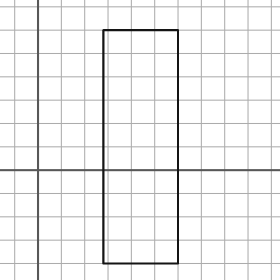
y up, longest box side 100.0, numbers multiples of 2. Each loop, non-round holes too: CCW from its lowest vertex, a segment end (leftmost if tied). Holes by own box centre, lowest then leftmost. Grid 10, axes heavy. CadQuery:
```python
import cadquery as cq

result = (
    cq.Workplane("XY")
    .moveTo(28.0, -40.0)
    .lineTo(60.0, -40.0)
    .lineTo(60.0, 60.0)
    .lineTo(28.0, 60.0)
    .close()
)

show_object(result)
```